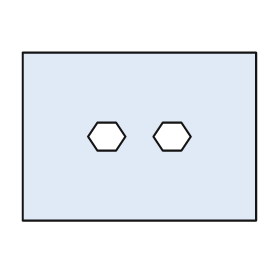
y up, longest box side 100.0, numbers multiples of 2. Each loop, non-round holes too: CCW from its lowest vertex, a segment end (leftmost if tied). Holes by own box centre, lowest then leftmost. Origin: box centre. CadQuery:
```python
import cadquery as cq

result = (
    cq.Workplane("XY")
    .moveTo(-50.0, -36.0)
    .lineTo(50.0, -36.0)
    .lineTo(50.0, 36.0)
    .lineTo(-50.0, 36.0)
    .close()
    .moveTo(-18.0, -6.0)
    .lineTo(-10.0, -6.0)
    .lineTo(-6.0, 0.0)
    .lineTo(-10.0, 6.0)
    .lineTo(-18.0, 6.0)
    .lineTo(-22.0, 0.0)
    .close()
    .moveTo(10.0, -6.0)
    .lineTo(18.0, -6.0)
    .lineTo(22.0, 0.0)
    .lineTo(18.0, 6.0)
    .lineTo(10.0, 6.0)
    .lineTo(6.0, 0.0)
    .close()
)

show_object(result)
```